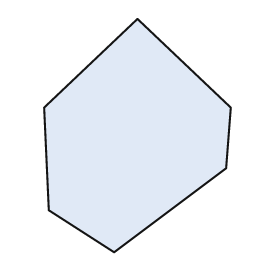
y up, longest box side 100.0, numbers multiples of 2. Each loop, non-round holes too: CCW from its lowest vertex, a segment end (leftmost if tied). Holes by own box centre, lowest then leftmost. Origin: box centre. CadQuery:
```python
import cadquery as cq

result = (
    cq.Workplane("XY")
    .moveTo(-10.0, -50.0)
    .lineTo(38.0, -14.0)
    .lineTo(40.0, 12.0)
    .lineTo(0.0, 50.0)
    .lineTo(-40.0, 12.0)
    .lineTo(-38.0, -32.0)
    .close()
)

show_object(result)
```